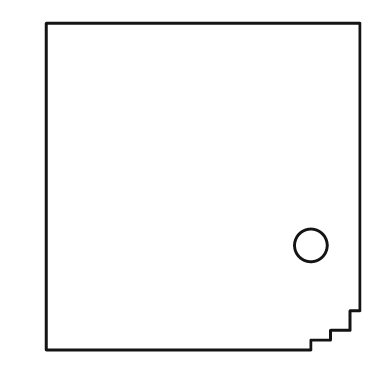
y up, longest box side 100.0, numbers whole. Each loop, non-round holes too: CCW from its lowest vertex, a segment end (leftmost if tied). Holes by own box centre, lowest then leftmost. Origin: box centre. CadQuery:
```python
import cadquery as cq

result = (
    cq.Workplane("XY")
    .moveTo(-48.0, -50.0)
    .lineTo(33.0, -50.0)
    .lineTo(33.0, -47.0)
    .lineTo(39.0, -47.0)
    .lineTo(39.0, -44.0)
    .lineTo(45.0, -44.0)
    .lineTo(45.0, -38.0)
    .lineTo(48.0, -38.0)
    .lineTo(48.0, 50.0)
    .lineTo(-48.0, 50.0)
    .close()
    .moveTo(33.0, -18.0)
    .circle(5.0)
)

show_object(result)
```